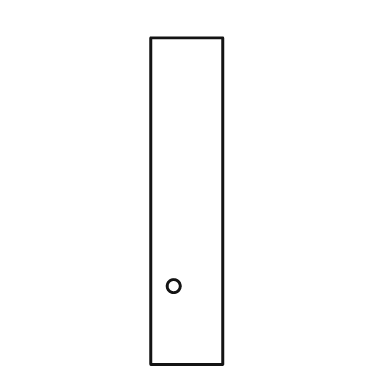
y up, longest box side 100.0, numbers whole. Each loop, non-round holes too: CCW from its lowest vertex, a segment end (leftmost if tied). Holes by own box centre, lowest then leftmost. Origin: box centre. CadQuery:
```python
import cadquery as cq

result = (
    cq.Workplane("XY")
    .moveTo(-11.0, -50.0)
    .lineTo(11.0, -50.0)
    .lineTo(11.0, 50.0)
    .lineTo(-11.0, 50.0)
    .close()
    .moveTo(-4.0, -26.0)
    .circle(2.0)
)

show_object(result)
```